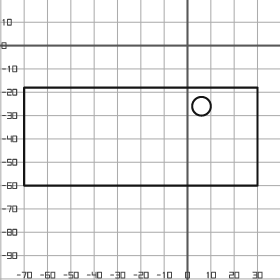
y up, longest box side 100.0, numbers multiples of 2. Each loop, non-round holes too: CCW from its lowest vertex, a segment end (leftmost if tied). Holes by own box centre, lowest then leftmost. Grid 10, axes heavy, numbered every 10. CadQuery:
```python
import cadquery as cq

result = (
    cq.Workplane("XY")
    .moveTo(-70.0, -60.0)
    .lineTo(30.0, -60.0)
    .lineTo(30.0, -18.0)
    .lineTo(-70.0, -18.0)
    .close()
    .moveTo(6.0, -26.0)
    .circle(4.0)
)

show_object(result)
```